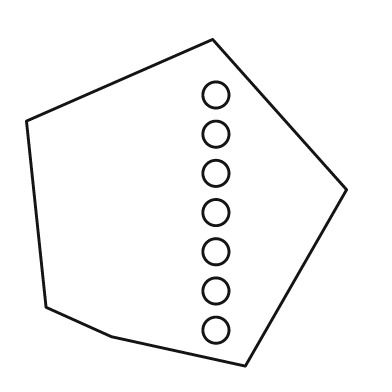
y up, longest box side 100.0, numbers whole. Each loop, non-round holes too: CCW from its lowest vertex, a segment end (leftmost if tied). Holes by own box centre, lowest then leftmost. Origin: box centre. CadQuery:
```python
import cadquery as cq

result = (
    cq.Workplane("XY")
    .moveTo(18.0, -50.0)
    .lineTo(49.0, 4.0)
    .lineTo(8.0, 50.0)
    .lineTo(-49.0, 25.0)
    .lineTo(-43.0, -32.0)
    .lineTo(-23.0, -41.0)
    .close()
    .moveTo(9.0, -39.0)
    .circle(4.0)
    .moveTo(9.0, -27.0)
    .circle(4.0)
    .moveTo(9.0, -15.0)
    .circle(4.0)
    .moveTo(9.0, -3.0)
    .circle(4.0)
    .moveTo(9.0, 9.0)
    .circle(4.0)
    .moveTo(9.0, 21.0)
    .circle(4.0)
    .moveTo(9.0, 33.0)
    .circle(4.0)
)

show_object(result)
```